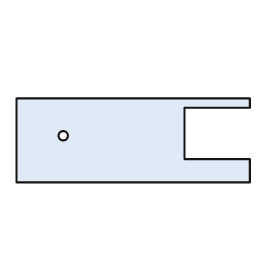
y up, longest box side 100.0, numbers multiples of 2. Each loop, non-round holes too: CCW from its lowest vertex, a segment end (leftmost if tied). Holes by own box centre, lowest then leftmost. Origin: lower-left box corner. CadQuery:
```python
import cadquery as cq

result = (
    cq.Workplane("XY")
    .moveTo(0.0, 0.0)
    .lineTo(100.0, 0.0)
    .lineTo(100.0, 10.0)
    .lineTo(72.0, 10.0)
    .lineTo(72.0, 32.0)
    .lineTo(100.0, 32.0)
    .lineTo(100.0, 36.0)
    .lineTo(0.0, 36.0)
    .close()
    .moveTo(20.0, 20.0)
    .circle(2.0)
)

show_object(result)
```